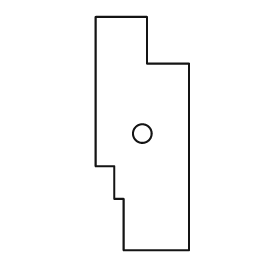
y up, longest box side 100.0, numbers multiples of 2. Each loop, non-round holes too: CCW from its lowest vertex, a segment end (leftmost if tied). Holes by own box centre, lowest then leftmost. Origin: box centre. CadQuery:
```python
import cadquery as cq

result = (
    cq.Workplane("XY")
    .moveTo(-8.0, -50.0)
    .lineTo(20.0, -50.0)
    .lineTo(20.0, 30.0)
    .lineTo(2.0, 30.0)
    .lineTo(2.0, 50.0)
    .lineTo(-20.0, 50.0)
    .lineTo(-20.0, -14.0)
    .lineTo(-12.0, -14.0)
    .lineTo(-12.0, -28.0)
    .lineTo(-8.0, -28.0)
    .close()
    .moveTo(0.0, 0.0)
    .circle(4.0)
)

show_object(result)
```